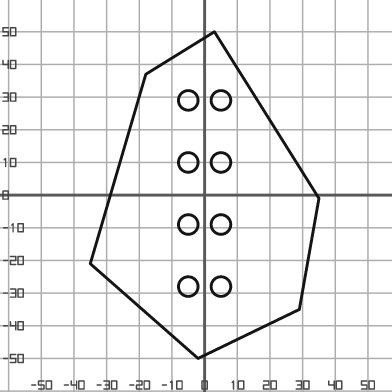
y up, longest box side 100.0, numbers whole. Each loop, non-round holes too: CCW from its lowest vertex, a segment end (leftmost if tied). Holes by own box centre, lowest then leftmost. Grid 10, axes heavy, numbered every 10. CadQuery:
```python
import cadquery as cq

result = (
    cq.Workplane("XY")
    .moveTo(-2.0, -50.0)
    .lineTo(29.0, -35.0)
    .lineTo(35.0, -1.0)
    .lineTo(3.0, 50.0)
    .lineTo(-18.0, 37.0)
    .lineTo(-35.0, -21.0)
    .close()
    .moveTo(-5.0, -28.0)
    .circle(3.0)
    .moveTo(5.0, -28.0)
    .circle(3.0)
    .moveTo(-5.0, -9.0)
    .circle(3.0)
    .moveTo(5.0, -9.0)
    .circle(3.0)
    .moveTo(-5.0, 10.0)
    .circle(3.0)
    .moveTo(5.0, 10.0)
    .circle(3.0)
    .moveTo(-5.0, 29.0)
    .circle(3.0)
    .moveTo(5.0, 29.0)
    .circle(3.0)
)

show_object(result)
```